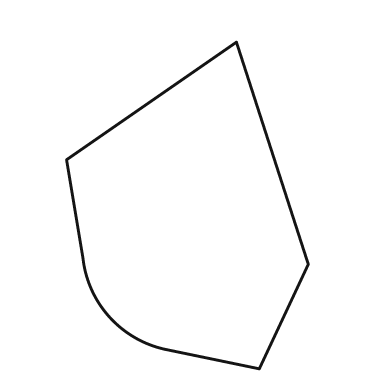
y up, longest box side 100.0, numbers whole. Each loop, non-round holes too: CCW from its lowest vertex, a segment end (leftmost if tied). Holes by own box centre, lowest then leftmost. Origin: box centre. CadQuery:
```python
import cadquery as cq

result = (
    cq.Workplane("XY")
    .moveTo(22.0, -50.0)
    .lineTo(37.0, -18.0)
    .lineTo(15.0, 50.0)
    .lineTo(-37.0, 14.0)
    .lineTo(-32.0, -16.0)
    .threePointArc((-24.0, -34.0), (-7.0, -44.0))
    .close()
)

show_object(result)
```